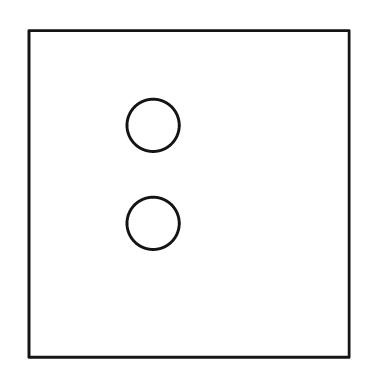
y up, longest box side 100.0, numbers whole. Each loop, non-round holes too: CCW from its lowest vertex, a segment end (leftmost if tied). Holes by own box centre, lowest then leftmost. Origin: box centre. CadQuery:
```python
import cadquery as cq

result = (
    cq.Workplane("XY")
    .moveTo(-49.0, -50.0)
    .lineTo(49.0, -50.0)
    .lineTo(49.0, 50.0)
    .lineTo(-49.0, 50.0)
    .close()
    .moveTo(-11.0, -9.0)
    .circle(8.0)
    .moveTo(-11.0, 21.0)
    .circle(8.0)
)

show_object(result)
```